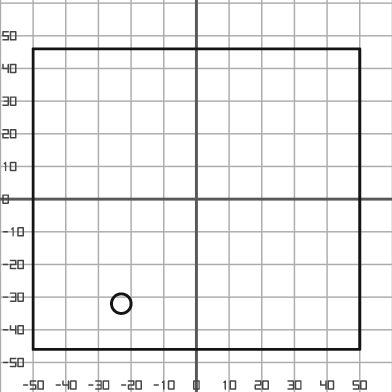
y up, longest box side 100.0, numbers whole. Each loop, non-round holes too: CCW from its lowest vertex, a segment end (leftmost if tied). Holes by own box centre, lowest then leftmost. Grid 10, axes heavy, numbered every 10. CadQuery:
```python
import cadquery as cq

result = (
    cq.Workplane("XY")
    .moveTo(-50.0, -46.0)
    .lineTo(50.0, -46.0)
    .lineTo(50.0, 46.0)
    .lineTo(-50.0, 46.0)
    .close()
    .moveTo(-23.0, -32.0)
    .circle(3.0)
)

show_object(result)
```